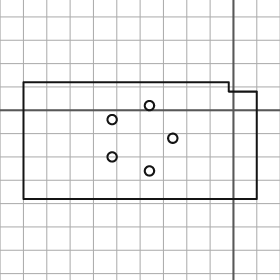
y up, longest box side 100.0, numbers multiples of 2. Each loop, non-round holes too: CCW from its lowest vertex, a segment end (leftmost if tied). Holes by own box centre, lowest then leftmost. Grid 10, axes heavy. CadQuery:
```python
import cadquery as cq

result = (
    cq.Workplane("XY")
    .moveTo(-90.0, -38.0)
    .lineTo(10.0, -38.0)
    .lineTo(10.0, 8.0)
    .lineTo(-2.0, 8.0)
    .lineTo(-2.0, 12.0)
    .lineTo(-90.0, 12.0)
    .close()
    .moveTo(-36.0, -26.0)
    .circle(2.0)
    .moveTo(-52.0, -20.0)
    .circle(2.0)
    .moveTo(-26.0, -12.0)
    .circle(2.0)
    .moveTo(-52.0, -4.0)
    .circle(2.0)
    .moveTo(-36.0, 2.0)
    .circle(2.0)
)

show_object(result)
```